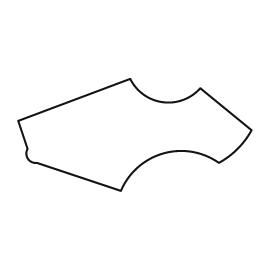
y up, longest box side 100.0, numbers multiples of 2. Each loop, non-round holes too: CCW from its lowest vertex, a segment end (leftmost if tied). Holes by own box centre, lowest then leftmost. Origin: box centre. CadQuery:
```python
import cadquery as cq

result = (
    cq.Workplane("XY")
    .moveTo(-6.0, -24.0)
    .threePointArc((12.0, -8.0), (36.0, -12.0))
    .threePointArc((44.0, -6.0), (50.0, 2.0))
    .lineTo(28.0, 20.0)
    .threePointArc((12.0, 14.0), (-2.0, 24.0))
    .lineTo(-50.0, 6.0)
    .lineTo(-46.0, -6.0)
    .threePointArc((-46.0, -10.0), (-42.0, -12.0))
    .close()
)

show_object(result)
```